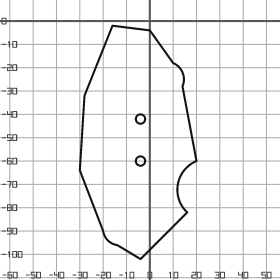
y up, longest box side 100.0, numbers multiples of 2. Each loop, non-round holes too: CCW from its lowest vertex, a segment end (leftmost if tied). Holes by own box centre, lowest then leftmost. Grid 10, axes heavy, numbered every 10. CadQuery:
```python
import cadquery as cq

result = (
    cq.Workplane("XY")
    .moveTo(-4.0, -102.0)
    .lineTo(16.0, -82.0)
    .threePointArc((12.0, -70.0), (20.0, -60.0))
    .lineTo(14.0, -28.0)
    .threePointArc((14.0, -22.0), (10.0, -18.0))
    .lineTo(0.0, -4.0)
    .lineTo(-16.0, -2.0)
    .lineTo(-28.0, -32.0)
    .lineTo(-30.0, -64.0)
    .lineTo(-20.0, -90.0)
    .threePointArc((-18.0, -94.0), (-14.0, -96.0))
    .close()
    .moveTo(-4.0, -60.0)
    .circle(2.0)
    .moveTo(-4.0, -42.0)
    .circle(2.0)
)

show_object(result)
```